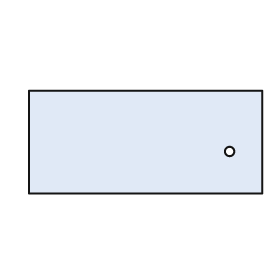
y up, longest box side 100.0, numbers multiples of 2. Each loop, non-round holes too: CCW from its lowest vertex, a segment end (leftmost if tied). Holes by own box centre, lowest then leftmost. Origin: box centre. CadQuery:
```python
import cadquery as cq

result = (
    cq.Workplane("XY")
    .moveTo(-50.0, -22.0)
    .lineTo(50.0, -22.0)
    .lineTo(50.0, 22.0)
    .lineTo(-50.0, 22.0)
    .close()
    .moveTo(36.0, -4.0)
    .circle(2.0)
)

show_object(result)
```